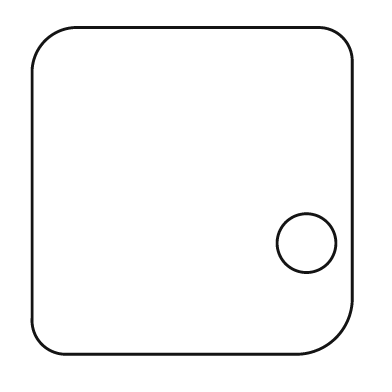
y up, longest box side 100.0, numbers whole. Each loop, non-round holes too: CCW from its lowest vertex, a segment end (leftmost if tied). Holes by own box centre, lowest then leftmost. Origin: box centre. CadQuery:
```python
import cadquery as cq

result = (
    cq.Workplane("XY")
    .moveTo(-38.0, -50.0)
    .lineTo(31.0, -50.0)
    .threePointArc((44.0, -45.0), (49.0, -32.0))
    .lineTo(49.0, 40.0)
    .threePointArc((46.0, 47.0), (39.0, 50.0))
    .lineTo(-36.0, 50.0)
    .threePointArc((-45.0, 46.0), (-49.0, 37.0))
    .lineTo(-49.0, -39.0)
    .threePointArc((-46.0, -47.0), (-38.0, -50.0))
    .close()
    .moveTo(35.0, -16.0)
    .circle(9.0)
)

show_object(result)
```